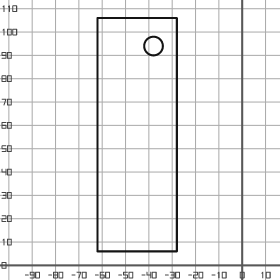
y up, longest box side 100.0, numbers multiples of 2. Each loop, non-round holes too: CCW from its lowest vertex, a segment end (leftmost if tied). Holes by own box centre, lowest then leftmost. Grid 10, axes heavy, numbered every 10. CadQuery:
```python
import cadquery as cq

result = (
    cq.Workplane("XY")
    .moveTo(-62.0, 6.0)
    .lineTo(-28.0, 6.0)
    .lineTo(-28.0, 106.0)
    .lineTo(-62.0, 106.0)
    .close()
    .moveTo(-38.0, 94.0)
    .circle(4.0)
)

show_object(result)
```